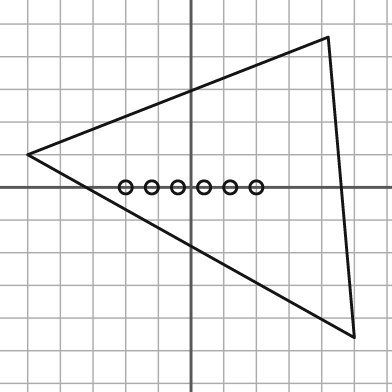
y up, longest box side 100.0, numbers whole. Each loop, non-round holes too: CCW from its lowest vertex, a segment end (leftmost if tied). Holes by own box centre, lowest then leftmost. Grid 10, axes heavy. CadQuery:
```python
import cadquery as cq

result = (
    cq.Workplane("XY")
    .moveTo(50.0, -46.0)
    .lineTo(42.0, 46.0)
    .lineTo(-50.0, 10.0)
    .close()
    .moveTo(-20.0, 0.0)
    .circle(2.0)
    .moveTo(-12.0, 0.0)
    .circle(2.0)
    .moveTo(-4.0, 0.0)
    .circle(2.0)
    .moveTo(4.0, 0.0)
    .circle(2.0)
    .moveTo(12.0, 0.0)
    .circle(2.0)
    .moveTo(20.0, 0.0)
    .circle(2.0)
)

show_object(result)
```